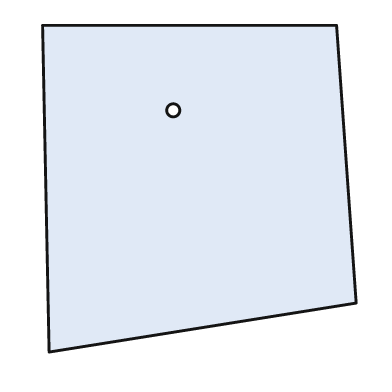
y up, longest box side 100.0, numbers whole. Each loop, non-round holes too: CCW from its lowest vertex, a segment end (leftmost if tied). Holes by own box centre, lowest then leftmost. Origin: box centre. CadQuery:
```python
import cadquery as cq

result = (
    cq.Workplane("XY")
    .moveTo(-46.0, -50.0)
    .lineTo(48.0, -35.0)
    .lineTo(42.0, 50.0)
    .lineTo(-48.0, 50.0)
    .close()
    .moveTo(-8.0, 24.0)
    .circle(2.0)
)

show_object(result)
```